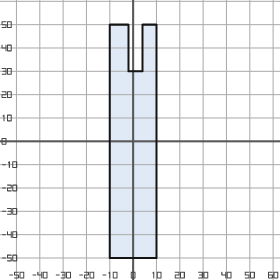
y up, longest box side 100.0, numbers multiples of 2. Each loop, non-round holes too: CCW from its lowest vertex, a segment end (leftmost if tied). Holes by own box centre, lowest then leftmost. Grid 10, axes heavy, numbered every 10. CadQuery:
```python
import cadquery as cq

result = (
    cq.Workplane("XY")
    .moveTo(-10.0, -50.0)
    .lineTo(10.0, -50.0)
    .lineTo(10.0, 50.0)
    .lineTo(4.0, 50.0)
    .lineTo(4.0, 30.0)
    .lineTo(-2.0, 30.0)
    .lineTo(-2.0, 50.0)
    .lineTo(-10.0, 50.0)
    .close()
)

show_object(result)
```